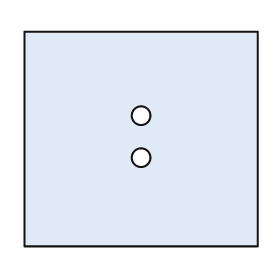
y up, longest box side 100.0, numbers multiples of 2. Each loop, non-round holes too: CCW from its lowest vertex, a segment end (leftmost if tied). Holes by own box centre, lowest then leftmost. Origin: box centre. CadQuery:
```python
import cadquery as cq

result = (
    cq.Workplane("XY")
    .moveTo(-50.0, -46.0)
    .lineTo(50.0, -46.0)
    .lineTo(50.0, 46.0)
    .lineTo(-50.0, 46.0)
    .close()
    .moveTo(0.0, -8.0)
    .circle(4.0)
    .moveTo(0.0, 10.0)
    .circle(4.0)
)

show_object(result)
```